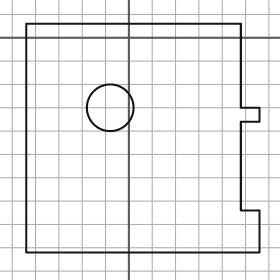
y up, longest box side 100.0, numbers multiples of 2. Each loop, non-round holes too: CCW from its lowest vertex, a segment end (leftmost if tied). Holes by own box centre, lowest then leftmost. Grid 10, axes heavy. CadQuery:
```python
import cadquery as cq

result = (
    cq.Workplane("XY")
    .moveTo(-44.0, -92.0)
    .lineTo(56.0, -92.0)
    .lineTo(56.0, -74.0)
    .lineTo(48.0, -74.0)
    .lineTo(48.0, -36.0)
    .lineTo(56.0, -36.0)
    .lineTo(56.0, -30.0)
    .lineTo(48.0, -30.0)
    .lineTo(48.0, 6.0)
    .lineTo(-44.0, 6.0)
    .close()
    .moveTo(-8.0, -30.0)
    .circle(10.0)
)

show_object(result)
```